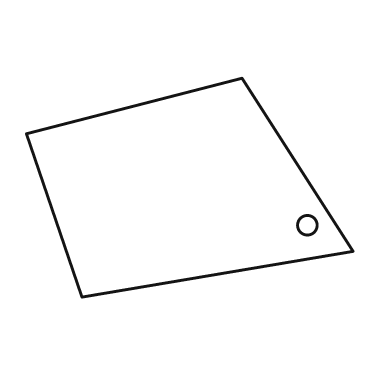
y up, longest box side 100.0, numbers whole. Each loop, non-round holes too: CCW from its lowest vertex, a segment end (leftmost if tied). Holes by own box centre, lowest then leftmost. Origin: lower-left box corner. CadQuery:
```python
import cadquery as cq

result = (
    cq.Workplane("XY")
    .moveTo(17.0, 0.0)
    .lineTo(100.0, 14.0)
    .lineTo(66.0, 67.0)
    .lineTo(0.0, 50.0)
    .close()
    .moveTo(86.0, 22.0)
    .circle(3.0)
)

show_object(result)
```